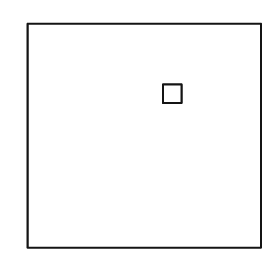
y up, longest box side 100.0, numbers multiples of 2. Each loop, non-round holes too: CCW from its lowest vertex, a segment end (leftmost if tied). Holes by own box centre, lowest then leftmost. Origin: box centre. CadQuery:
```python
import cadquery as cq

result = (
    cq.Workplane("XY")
    .moveTo(-50.0, -48.0)
    .lineTo(50.0, -48.0)
    .lineTo(50.0, 48.0)
    .lineTo(-50.0, 48.0)
    .close()
    .moveTo(8.0, 14.0)
    .lineTo(16.0, 14.0)
    .lineTo(16.0, 22.0)
    .lineTo(8.0, 22.0)
    .close()
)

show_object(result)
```